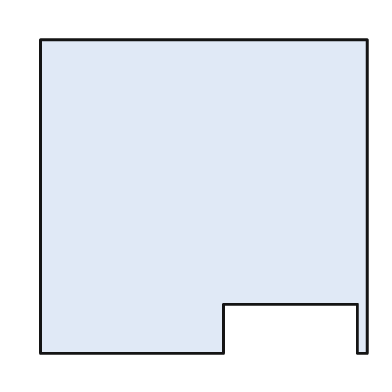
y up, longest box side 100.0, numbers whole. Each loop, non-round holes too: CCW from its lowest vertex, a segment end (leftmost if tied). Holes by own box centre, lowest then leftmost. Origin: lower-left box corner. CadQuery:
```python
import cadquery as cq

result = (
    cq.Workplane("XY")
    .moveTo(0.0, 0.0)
    .lineTo(56.0, 0.0)
    .lineTo(56.0, 15.0)
    .lineTo(97.0, 15.0)
    .lineTo(97.0, 0.0)
    .lineTo(100.0, 0.0)
    .lineTo(100.0, 96.0)
    .lineTo(0.0, 96.0)
    .close()
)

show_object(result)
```